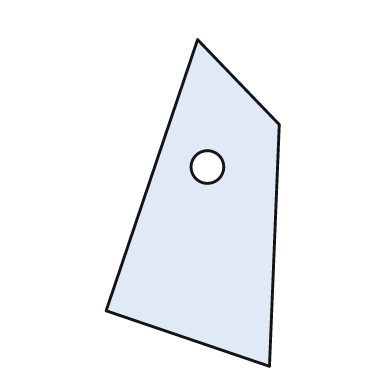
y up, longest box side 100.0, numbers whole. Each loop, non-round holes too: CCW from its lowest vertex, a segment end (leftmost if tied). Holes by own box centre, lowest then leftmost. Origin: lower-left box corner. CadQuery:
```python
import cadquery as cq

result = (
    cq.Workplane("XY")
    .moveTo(50.0, 0.0)
    .lineTo(53.0, 74.0)
    .lineTo(28.0, 100.0)
    .lineTo(0.0, 17.0)
    .close()
    .moveTo(31.0, 61.0)
    .circle(5.0)
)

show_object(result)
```